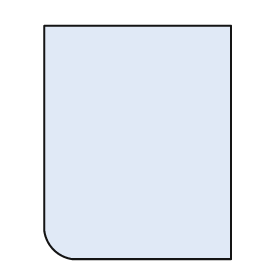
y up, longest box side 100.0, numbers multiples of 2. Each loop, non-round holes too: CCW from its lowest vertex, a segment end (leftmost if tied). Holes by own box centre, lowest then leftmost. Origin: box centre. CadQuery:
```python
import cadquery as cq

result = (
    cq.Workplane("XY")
    .moveTo(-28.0, -50.0)
    .lineTo(40.0, -50.0)
    .lineTo(40.0, 50.0)
    .lineTo(-40.0, 50.0)
    .lineTo(-40.0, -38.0)
    .threePointArc((-36.0, -46.0), (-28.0, -50.0))
    .close()
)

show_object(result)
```